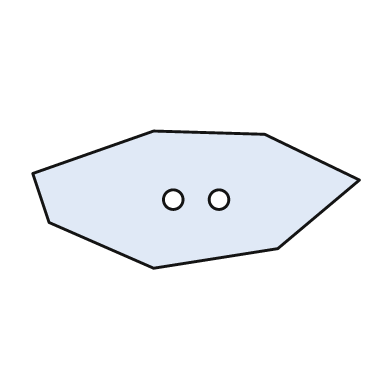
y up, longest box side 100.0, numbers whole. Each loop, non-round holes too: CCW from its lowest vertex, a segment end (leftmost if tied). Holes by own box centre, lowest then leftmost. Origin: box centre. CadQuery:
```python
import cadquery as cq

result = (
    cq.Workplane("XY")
    .moveTo(-13.0, -21.0)
    .lineTo(25.0, -15.0)
    .lineTo(50.0, 6.0)
    .lineTo(21.0, 20.0)
    .lineTo(-13.0, 21.0)
    .lineTo(-50.0, 8.0)
    .lineTo(-45.0, -7.0)
    .close()
    .moveTo(-7.0, 0.0)
    .circle(3.0)
    .moveTo(7.0, 0.0)
    .circle(3.0)
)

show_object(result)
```